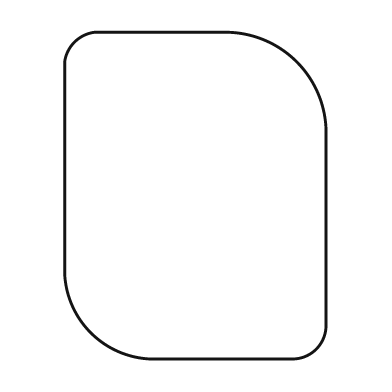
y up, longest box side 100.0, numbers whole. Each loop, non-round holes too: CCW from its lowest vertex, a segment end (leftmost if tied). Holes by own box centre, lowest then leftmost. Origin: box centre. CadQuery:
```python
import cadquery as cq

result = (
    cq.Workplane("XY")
    .moveTo(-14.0, -50.0)
    .lineTo(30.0, -50.0)
    .threePointArc((37.0, -47.0), (40.0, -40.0))
    .lineTo(40.0, 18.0)
    .threePointArc((31.0, 41.0), (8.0, 50.0))
    .lineTo(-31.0, 50.0)
    .threePointArc((-37.0, 47.0), (-40.0, 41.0))
    .lineTo(-40.0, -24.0)
    .threePointArc((-32.0, -42.0), (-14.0, -50.0))
    .close()
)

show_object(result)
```